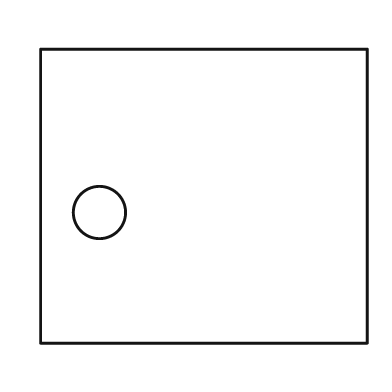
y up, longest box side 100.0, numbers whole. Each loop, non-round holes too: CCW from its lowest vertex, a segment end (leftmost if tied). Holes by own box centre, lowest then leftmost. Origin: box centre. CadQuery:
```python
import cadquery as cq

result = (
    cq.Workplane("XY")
    .moveTo(-50.0, -45.0)
    .lineTo(50.0, -45.0)
    .lineTo(50.0, 45.0)
    .lineTo(-50.0, 45.0)
    .close()
    .moveTo(-32.0, -5.0)
    .circle(8.0)
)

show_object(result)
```